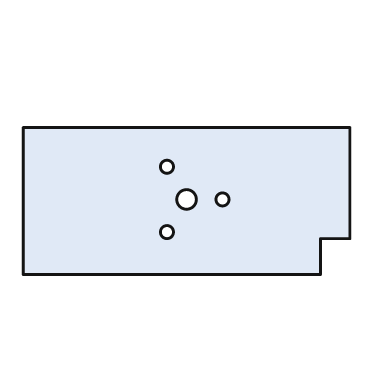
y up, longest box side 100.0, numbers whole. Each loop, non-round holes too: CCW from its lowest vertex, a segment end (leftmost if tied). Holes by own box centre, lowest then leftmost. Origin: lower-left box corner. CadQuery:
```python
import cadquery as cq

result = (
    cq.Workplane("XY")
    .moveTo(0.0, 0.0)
    .lineTo(91.0, 0.0)
    .lineTo(91.0, 11.0)
    .lineTo(100.0, 11.0)
    .lineTo(100.0, 45.0)
    .lineTo(0.0, 45.0)
    .close()
    .moveTo(44.0, 13.0)
    .circle(2.0)
    .moveTo(50.0, 23.0)
    .circle(3.0)
    .moveTo(61.0, 23.0)
    .circle(2.0)
    .moveTo(44.0, 33.0)
    .circle(2.0)
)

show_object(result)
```